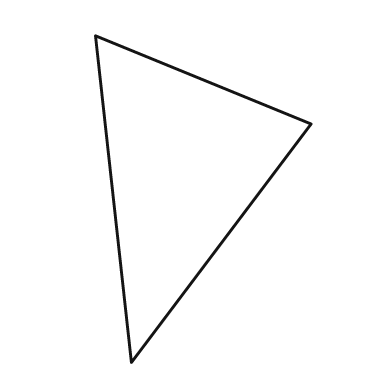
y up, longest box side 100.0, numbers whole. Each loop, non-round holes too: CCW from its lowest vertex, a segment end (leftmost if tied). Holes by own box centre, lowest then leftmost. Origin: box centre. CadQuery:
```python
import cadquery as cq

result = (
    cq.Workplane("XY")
    .moveTo(-22.0, -50.0)
    .lineTo(33.0, 23.0)
    .lineTo(-33.0, 50.0)
    .close()
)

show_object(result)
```